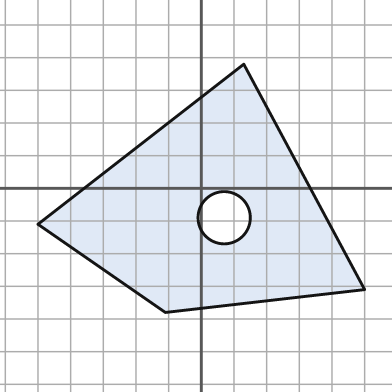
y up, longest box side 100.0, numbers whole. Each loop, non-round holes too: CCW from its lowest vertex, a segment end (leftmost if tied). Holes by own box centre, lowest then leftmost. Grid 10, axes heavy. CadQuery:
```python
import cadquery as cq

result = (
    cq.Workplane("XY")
    .moveTo(-11.0, -38.0)
    .lineTo(50.0, -31.0)
    .lineTo(13.0, 38.0)
    .lineTo(-50.0, -11.0)
    .close()
    .moveTo(7.0, -9.0)
    .circle(8.0)
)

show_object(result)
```